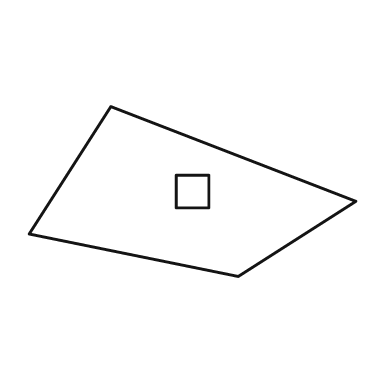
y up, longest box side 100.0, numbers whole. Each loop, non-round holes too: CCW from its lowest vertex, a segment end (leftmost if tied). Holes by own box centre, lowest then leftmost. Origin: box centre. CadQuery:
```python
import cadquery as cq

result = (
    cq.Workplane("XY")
    .moveTo(14.0, -26.0)
    .lineTo(50.0, -3.0)
    .lineTo(-25.0, 26.0)
    .lineTo(-50.0, -13.0)
    .close()
    .moveTo(-5.0, -5.0)
    .lineTo(5.0, -5.0)
    .lineTo(5.0, 5.0)
    .lineTo(-5.0, 5.0)
    .close()
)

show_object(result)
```